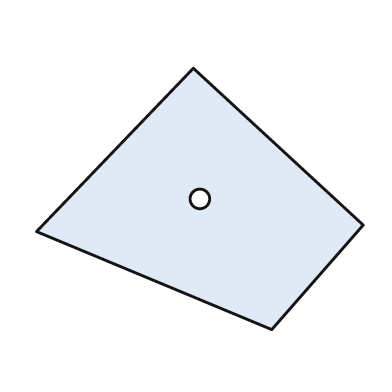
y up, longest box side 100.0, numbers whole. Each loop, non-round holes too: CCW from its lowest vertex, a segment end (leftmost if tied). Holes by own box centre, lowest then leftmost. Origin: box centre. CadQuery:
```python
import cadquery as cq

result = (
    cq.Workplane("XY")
    .moveTo(22.0, -40.0)
    .lineTo(50.0, -8.0)
    .lineTo(-2.0, 40.0)
    .lineTo(-50.0, -10.0)
    .close()
    .moveTo(0.0, 0.0)
    .circle(3.0)
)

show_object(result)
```